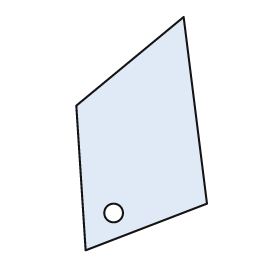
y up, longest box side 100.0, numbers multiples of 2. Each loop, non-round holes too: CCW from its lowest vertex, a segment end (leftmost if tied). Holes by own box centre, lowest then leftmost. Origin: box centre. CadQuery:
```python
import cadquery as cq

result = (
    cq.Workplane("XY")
    .moveTo(-24.0, -50.0)
    .lineTo(28.0, -30.0)
    .lineTo(18.0, 50.0)
    .lineTo(-28.0, 12.0)
    .close()
    .moveTo(-12.0, -34.0)
    .circle(4.0)
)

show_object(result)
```